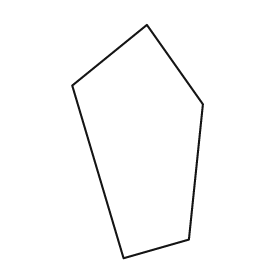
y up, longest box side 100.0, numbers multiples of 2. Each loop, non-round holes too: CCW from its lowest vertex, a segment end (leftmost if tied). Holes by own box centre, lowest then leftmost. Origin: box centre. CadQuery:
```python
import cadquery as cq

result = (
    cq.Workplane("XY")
    .moveTo(-6.0, -50.0)
    .lineTo(22.0, -42.0)
    .lineTo(28.0, 16.0)
    .lineTo(4.0, 50.0)
    .lineTo(-28.0, 24.0)
    .close()
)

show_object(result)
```